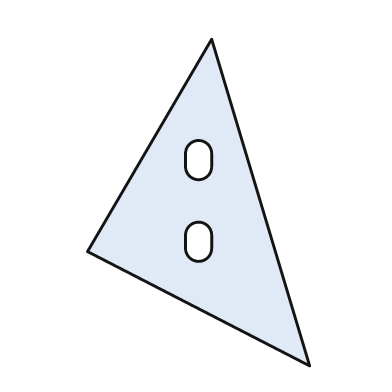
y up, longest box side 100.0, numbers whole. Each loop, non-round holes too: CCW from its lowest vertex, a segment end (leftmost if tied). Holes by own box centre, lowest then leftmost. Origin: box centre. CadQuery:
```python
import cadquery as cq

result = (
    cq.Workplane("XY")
    .moveTo(34.0, -50.0)
    .lineTo(4.0, 50.0)
    .lineTo(-34.0, -15.0)
    .close()
    .moveTo(-4.0, -14.0)
    .threePointArc((0.0, -18.0), (4.0, -14.0))
    .lineTo(4.0, -10.0)
    .threePointArc((0.0, -6.0), (-4.0, -10.0))
    .close()
    .moveTo(-4.0, 11.0)
    .threePointArc((0.0, 7.0), (4.0, 11.0))
    .lineTo(4.0, 15.0)
    .threePointArc((0.0, 19.0), (-4.0, 15.0))
    .close()
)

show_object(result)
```